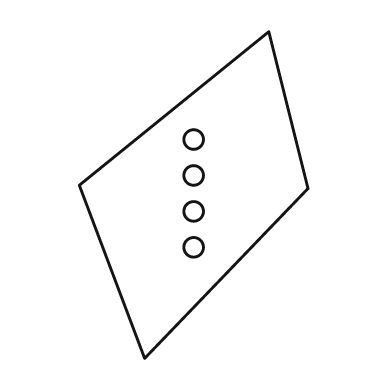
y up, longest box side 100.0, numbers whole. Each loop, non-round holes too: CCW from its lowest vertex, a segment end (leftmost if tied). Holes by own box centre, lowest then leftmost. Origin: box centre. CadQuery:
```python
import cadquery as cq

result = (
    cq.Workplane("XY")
    .moveTo(-15.0, -50.0)
    .lineTo(35.0, 2.0)
    .lineTo(23.0, 50.0)
    .lineTo(-35.0, 3.0)
    .close()
    .moveTo(0.0, -16.0)
    .circle(3.0)
    .moveTo(0.0, -5.0)
    .circle(3.0)
    .moveTo(0.0, 6.0)
    .circle(3.0)
    .moveTo(0.0, 17.0)
    .circle(3.0)
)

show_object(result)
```